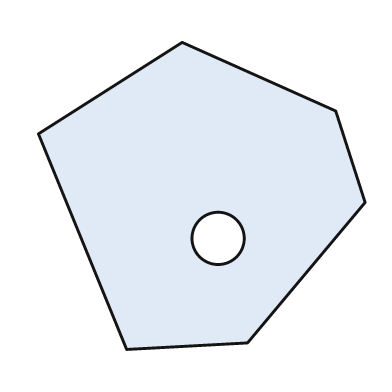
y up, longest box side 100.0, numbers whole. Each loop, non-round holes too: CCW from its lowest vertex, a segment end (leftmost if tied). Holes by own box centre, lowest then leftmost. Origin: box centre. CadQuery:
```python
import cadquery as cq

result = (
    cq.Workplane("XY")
    .moveTo(-23.0, -47.0)
    .lineTo(14.0, -45.0)
    .lineTo(50.0, -2.0)
    .lineTo(41.0, 26.0)
    .lineTo(-6.0, 47.0)
    .lineTo(-50.0, 19.0)
    .close()
    .moveTo(5.0, -13.0)
    .circle(8.0)
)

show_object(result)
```